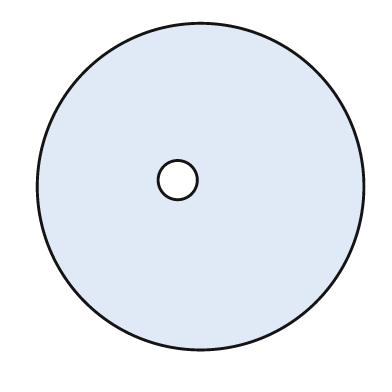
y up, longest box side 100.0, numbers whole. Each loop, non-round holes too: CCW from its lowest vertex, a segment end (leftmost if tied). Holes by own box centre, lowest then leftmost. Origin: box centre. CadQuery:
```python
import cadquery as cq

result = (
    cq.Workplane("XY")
    .moveTo(0.0, 0.0)
    .circle(50.0)
    .moveTo(-7.0, 2.0)
    .circle(6.0)
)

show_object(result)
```